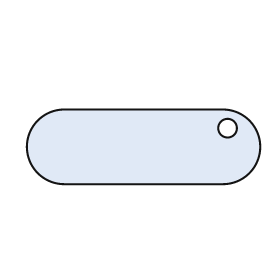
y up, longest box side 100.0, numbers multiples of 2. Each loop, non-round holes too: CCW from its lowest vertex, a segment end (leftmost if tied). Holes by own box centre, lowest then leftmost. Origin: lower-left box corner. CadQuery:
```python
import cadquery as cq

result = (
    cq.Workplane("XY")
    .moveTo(16.0, 0.0)
    .lineTo(84.0, 0.0)
    .threePointArc((100.0, 16.0), (84.0, 32.0))
    .lineTo(16.0, 32.0)
    .threePointArc((0.0, 16.0), (16.0, 0.0))
    .close()
    .moveTo(86.0, 24.0)
    .circle(4.0)
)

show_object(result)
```